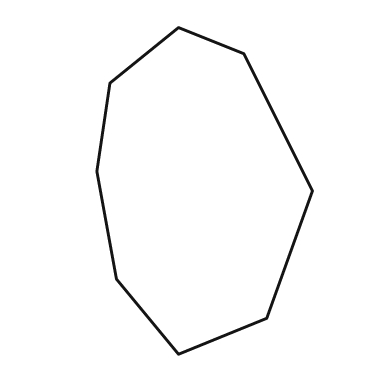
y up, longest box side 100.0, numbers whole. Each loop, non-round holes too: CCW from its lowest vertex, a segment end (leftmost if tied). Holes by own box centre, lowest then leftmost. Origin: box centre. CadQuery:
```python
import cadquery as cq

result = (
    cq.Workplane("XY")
    .moveTo(-8.0, -50.0)
    .lineTo(19.0, -39.0)
    .lineTo(33.0, 0.0)
    .lineTo(12.0, 42.0)
    .lineTo(-8.0, 50.0)
    .lineTo(-29.0, 33.0)
    .lineTo(-33.0, 6.0)
    .lineTo(-27.0, -27.0)
    .close()
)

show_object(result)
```